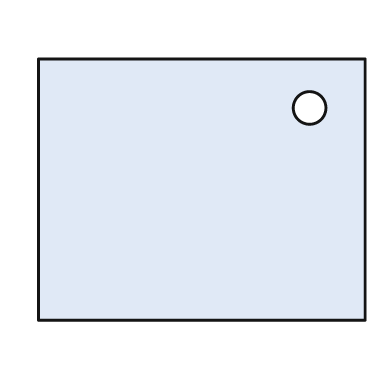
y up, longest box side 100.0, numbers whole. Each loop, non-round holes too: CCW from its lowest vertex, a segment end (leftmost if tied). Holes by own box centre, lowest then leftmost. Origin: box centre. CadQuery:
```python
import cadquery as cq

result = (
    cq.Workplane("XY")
    .moveTo(-50.0, -40.0)
    .lineTo(50.0, -40.0)
    .lineTo(50.0, 40.0)
    .lineTo(-50.0, 40.0)
    .close()
    .moveTo(33.0, 25.0)
    .circle(5.0)
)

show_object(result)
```